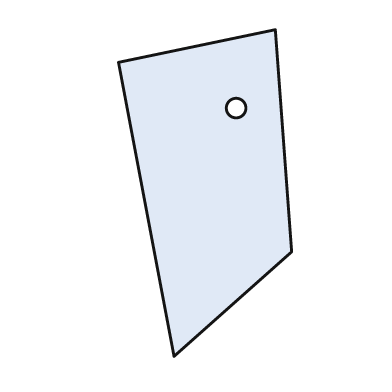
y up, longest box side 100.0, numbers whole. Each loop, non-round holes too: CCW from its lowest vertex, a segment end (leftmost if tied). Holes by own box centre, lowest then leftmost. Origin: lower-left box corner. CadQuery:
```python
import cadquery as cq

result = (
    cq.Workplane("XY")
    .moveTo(17.0, 0.0)
    .lineTo(53.0, 32.0)
    .lineTo(48.0, 100.0)
    .lineTo(0.0, 90.0)
    .close()
    .moveTo(36.0, 76.0)
    .circle(3.0)
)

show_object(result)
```